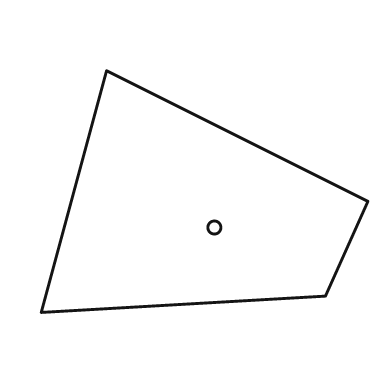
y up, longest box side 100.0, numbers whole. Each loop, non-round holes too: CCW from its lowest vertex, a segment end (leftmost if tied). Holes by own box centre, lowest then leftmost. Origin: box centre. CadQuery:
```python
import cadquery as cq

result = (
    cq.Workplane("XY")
    .moveTo(-50.0, -37.0)
    .lineTo(37.0, -32.0)
    .lineTo(50.0, -3.0)
    .lineTo(-30.0, 37.0)
    .close()
    .moveTo(3.0, -11.0)
    .circle(2.0)
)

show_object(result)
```